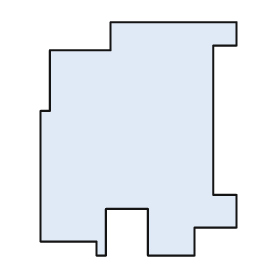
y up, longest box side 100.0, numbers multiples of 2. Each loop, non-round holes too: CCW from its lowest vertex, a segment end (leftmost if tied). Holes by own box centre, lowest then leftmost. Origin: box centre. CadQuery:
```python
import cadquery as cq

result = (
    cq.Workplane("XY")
    .moveTo(-18.0, -50.0)
    .lineTo(-14.0, -50.0)
    .lineTo(-14.0, -30.0)
    .lineTo(4.0, -30.0)
    .lineTo(4.0, -50.0)
    .lineTo(24.0, -50.0)
    .lineTo(24.0, -38.0)
    .lineTo(42.0, -38.0)
    .lineTo(42.0, -24.0)
    .lineTo(32.0, -24.0)
    .lineTo(32.0, 40.0)
    .lineTo(42.0, 40.0)
    .lineTo(42.0, 50.0)
    .lineTo(-12.0, 50.0)
    .lineTo(-12.0, 38.0)
    .lineTo(-38.0, 38.0)
    .lineTo(-38.0, 12.0)
    .lineTo(-42.0, 12.0)
    .lineTo(-42.0, -44.0)
    .lineTo(-18.0, -44.0)
    .close()
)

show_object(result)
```